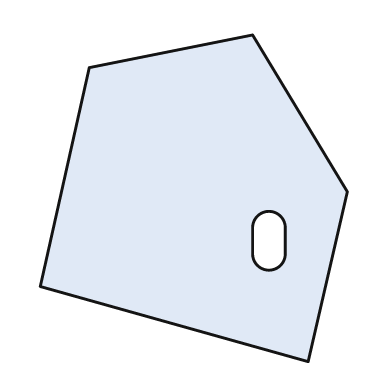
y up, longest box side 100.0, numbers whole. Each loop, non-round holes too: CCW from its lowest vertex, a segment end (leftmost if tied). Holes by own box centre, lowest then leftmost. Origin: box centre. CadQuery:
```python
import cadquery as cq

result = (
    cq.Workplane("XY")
    .moveTo(35.0, -50.0)
    .lineTo(47.0, 2.0)
    .lineTo(18.0, 50.0)
    .lineTo(-32.0, 40.0)
    .lineTo(-47.0, -27.0)
    .close()
    .moveTo(18.0, -17.0)
    .threePointArc((23.0, -22.0), (28.0, -17.0))
    .lineTo(28.0, -9.0)
    .threePointArc((23.0, -4.0), (18.0, -9.0))
    .close()
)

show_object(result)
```